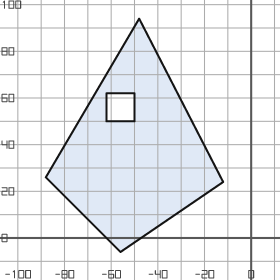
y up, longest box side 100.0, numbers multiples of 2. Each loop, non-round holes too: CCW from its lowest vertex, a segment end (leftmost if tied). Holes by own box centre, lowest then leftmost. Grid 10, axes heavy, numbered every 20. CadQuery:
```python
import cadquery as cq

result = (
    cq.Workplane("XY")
    .moveTo(-56.0, -6.0)
    .lineTo(-12.0, 24.0)
    .lineTo(-48.0, 94.0)
    .lineTo(-88.0, 26.0)
    .close()
    .moveTo(-62.0, 50.0)
    .lineTo(-50.0, 50.0)
    .lineTo(-50.0, 62.0)
    .lineTo(-62.0, 62.0)
    .close()
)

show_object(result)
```